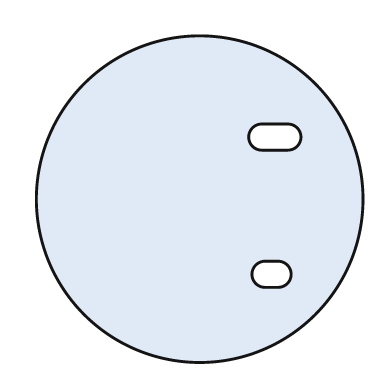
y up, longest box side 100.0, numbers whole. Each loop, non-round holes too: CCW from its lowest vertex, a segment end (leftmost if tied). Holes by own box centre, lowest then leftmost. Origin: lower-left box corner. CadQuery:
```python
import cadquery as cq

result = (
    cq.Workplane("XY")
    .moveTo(50.0, 50.0)
    .circle(50.0)
    .moveTo(70.0, 23.0)
    .lineTo(74.0, 23.0)
    .threePointArc((78.0, 27.0), (74.0, 31.0))
    .lineTo(70.0, 31.0)
    .threePointArc((66.0, 27.0), (70.0, 23.0))
    .close()
    .moveTo(69.0, 65.0)
    .lineTo(77.0, 65.0)
    .threePointArc((81.0, 69.0), (77.0, 73.0))
    .lineTo(69.0, 73.0)
    .threePointArc((65.0, 69.0), (69.0, 65.0))
    .close()
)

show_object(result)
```